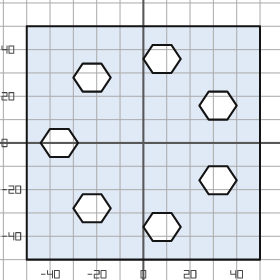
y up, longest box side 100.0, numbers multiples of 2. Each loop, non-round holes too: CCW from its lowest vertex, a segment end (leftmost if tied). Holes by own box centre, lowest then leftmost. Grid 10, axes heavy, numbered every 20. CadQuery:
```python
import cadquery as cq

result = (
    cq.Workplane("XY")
    .moveTo(-50.0, -50.0)
    .lineTo(50.0, -50.0)
    .lineTo(50.0, 50.0)
    .lineTo(-50.0, 50.0)
    .close()
    .moveTo(4.0, -42.0)
    .lineTo(12.0, -42.0)
    .lineTo(16.0, -36.0)
    .lineTo(12.0, -30.0)
    .lineTo(4.0, -30.0)
    .lineTo(0.0, -36.0)
    .close()
    .moveTo(-26.0, -34.0)
    .lineTo(-18.0, -34.0)
    .lineTo(-14.0, -28.0)
    .lineTo(-18.0, -22.0)
    .lineTo(-26.0, -22.0)
    .lineTo(-30.0, -28.0)
    .close()
    .moveTo(28.0, -22.0)
    .lineTo(36.0, -22.0)
    .lineTo(40.0, -16.0)
    .lineTo(36.0, -10.0)
    .lineTo(28.0, -10.0)
    .lineTo(24.0, -16.0)
    .close()
    .moveTo(-40.0, -6.0)
    .lineTo(-32.0, -6.0)
    .lineTo(-28.0, 0.0)
    .lineTo(-32.0, 6.0)
    .lineTo(-40.0, 6.0)
    .lineTo(-44.0, 0.0)
    .close()
    .moveTo(28.0, 10.0)
    .lineTo(36.0, 10.0)
    .lineTo(40.0, 16.0)
    .lineTo(36.0, 22.0)
    .lineTo(28.0, 22.0)
    .lineTo(24.0, 16.0)
    .close()
    .moveTo(-26.0, 22.0)
    .lineTo(-18.0, 22.0)
    .lineTo(-14.0, 28.0)
    .lineTo(-18.0, 34.0)
    .lineTo(-26.0, 34.0)
    .lineTo(-30.0, 28.0)
    .close()
    .moveTo(4.0, 30.0)
    .lineTo(12.0, 30.0)
    .lineTo(16.0, 36.0)
    .lineTo(12.0, 42.0)
    .lineTo(4.0, 42.0)
    .lineTo(0.0, 36.0)
    .close()
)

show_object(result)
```